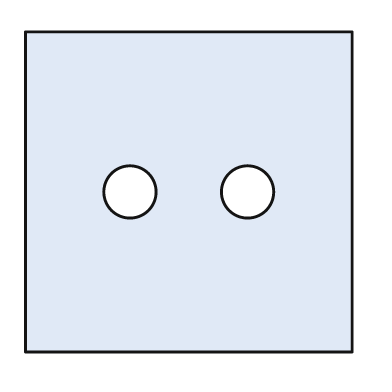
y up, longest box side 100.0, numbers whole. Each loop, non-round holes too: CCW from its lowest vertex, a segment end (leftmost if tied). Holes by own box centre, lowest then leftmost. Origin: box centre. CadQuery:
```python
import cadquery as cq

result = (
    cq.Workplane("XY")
    .moveTo(-50.0, -49.0)
    .lineTo(50.0, -49.0)
    .lineTo(50.0, 49.0)
    .lineTo(-50.0, 49.0)
    .close()
    .moveTo(-18.0, 0.0)
    .circle(8.0)
    .moveTo(18.0, 0.0)
    .circle(8.0)
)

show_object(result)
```